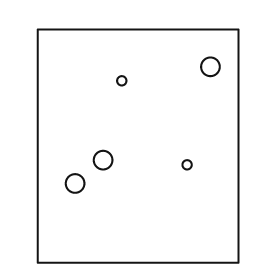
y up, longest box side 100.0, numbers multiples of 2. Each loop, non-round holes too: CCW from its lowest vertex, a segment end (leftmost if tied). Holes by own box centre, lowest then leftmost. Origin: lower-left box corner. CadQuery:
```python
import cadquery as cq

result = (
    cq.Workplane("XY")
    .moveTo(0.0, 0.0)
    .lineTo(86.0, 0.0)
    .lineTo(86.0, 100.0)
    .lineTo(0.0, 100.0)
    .close()
    .moveTo(16.0, 34.0)
    .circle(4.0)
    .moveTo(64.0, 42.0)
    .circle(2.0)
    .moveTo(28.0, 44.0)
    .circle(4.0)
    .moveTo(36.0, 78.0)
    .circle(2.0)
    .moveTo(74.0, 84.0)
    .circle(4.0)
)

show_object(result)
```